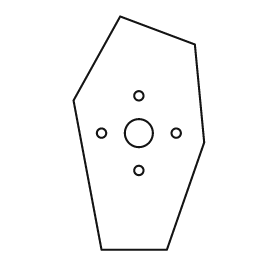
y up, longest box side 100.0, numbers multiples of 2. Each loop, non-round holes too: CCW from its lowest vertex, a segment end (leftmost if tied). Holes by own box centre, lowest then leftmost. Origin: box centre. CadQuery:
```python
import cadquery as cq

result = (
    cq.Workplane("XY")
    .moveTo(-16.0, -50.0)
    .lineTo(12.0, -50.0)
    .lineTo(28.0, -4.0)
    .lineTo(24.0, 38.0)
    .lineTo(-8.0, 50.0)
    .lineTo(-28.0, 14.0)
    .close()
    .moveTo(0.0, -16.0)
    .circle(2.0)
    .moveTo(-16.0, 0.0)
    .circle(2.0)
    .moveTo(0.0, 0.0)
    .circle(6.0)
    .moveTo(16.0, 0.0)
    .circle(2.0)
    .moveTo(0.0, 16.0)
    .circle(2.0)
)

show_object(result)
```